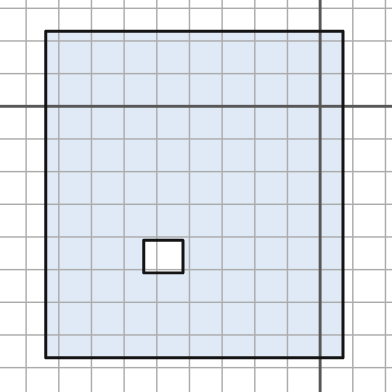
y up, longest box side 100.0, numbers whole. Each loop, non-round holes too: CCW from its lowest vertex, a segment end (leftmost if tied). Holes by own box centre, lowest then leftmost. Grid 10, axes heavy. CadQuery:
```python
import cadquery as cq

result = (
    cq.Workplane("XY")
    .moveTo(-84.0, -77.0)
    .lineTo(7.0, -77.0)
    .lineTo(7.0, 23.0)
    .lineTo(-84.0, 23.0)
    .close()
    .moveTo(-54.0, -51.0)
    .lineTo(-42.0, -51.0)
    .lineTo(-42.0, -41.0)
    .lineTo(-54.0, -41.0)
    .close()
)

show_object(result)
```